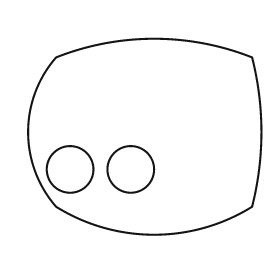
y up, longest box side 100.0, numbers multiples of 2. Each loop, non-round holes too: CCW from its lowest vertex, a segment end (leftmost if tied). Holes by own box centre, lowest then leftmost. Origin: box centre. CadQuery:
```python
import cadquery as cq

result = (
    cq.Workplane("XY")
    .moveTo(-38.0, -30.0)
    .threePointArc((4.0, -42.0), (46.0, -30.0))
    .threePointArc((50.0, 2.0), (46.0, 34.0))
    .threePointArc((4.0, 42.0), (-38.0, 34.0))
    .threePointArc((-50.0, 2.0), (-38.0, -30.0))
    .close()
    .moveTo(-32.0, -14.0)
    .circle(10.0)
    .moveTo(-6.0, -14.0)
    .circle(10.0)
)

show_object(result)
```